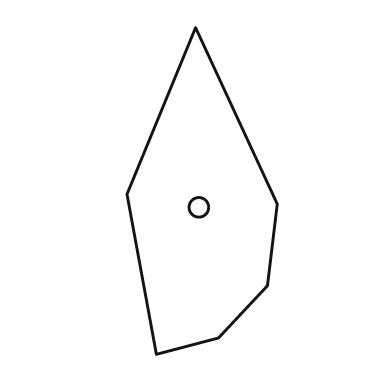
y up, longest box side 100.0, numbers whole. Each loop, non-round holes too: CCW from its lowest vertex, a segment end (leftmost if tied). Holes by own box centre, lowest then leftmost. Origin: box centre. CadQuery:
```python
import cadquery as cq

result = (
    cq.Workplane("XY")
    .moveTo(-14.0, -50.0)
    .lineTo(5.0, -45.0)
    .lineTo(20.0, -29.0)
    .lineTo(23.0, -4.0)
    .lineTo(-2.0, 50.0)
    .lineTo(-23.0, -1.0)
    .close()
    .moveTo(-1.0, -5.0)
    .circle(3.0)
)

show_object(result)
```